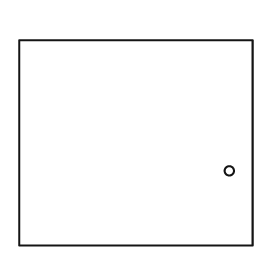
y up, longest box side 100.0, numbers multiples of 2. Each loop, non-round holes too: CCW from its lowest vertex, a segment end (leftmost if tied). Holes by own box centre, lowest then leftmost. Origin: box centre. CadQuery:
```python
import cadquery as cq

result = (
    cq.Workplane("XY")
    .moveTo(-50.0, -44.0)
    .lineTo(50.0, -44.0)
    .lineTo(50.0, 44.0)
    .lineTo(-50.0, 44.0)
    .close()
    .moveTo(40.0, -12.0)
    .circle(2.0)
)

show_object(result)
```